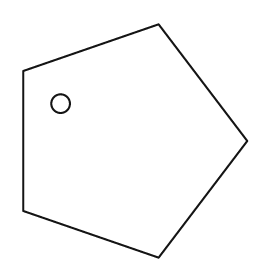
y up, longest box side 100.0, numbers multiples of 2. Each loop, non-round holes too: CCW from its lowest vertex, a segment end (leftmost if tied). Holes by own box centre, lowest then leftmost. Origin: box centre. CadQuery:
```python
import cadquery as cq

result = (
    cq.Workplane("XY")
    .moveTo(10.0, -50.0)
    .lineTo(48.0, 0.0)
    .lineTo(10.0, 50.0)
    .lineTo(-48.0, 30.0)
    .lineTo(-48.0, -30.0)
    .close()
    .moveTo(-32.0, 16.0)
    .circle(4.0)
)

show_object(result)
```